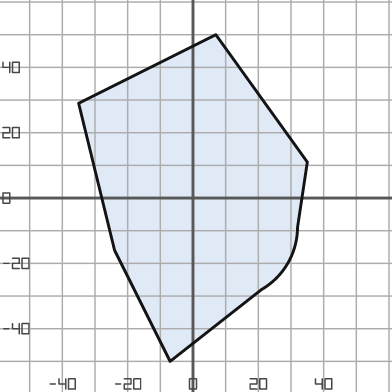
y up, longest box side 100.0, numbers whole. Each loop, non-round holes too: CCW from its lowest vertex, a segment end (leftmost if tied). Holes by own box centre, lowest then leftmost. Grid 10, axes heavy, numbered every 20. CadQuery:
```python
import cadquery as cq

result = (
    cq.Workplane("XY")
    .moveTo(-7.0, -50.0)
    .lineTo(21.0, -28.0)
    .threePointArc((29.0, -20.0), (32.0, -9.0))
    .lineTo(35.0, 11.0)
    .lineTo(7.0, 50.0)
    .lineTo(-35.0, 29.0)
    .lineTo(-24.0, -16.0)
    .close()
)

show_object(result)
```